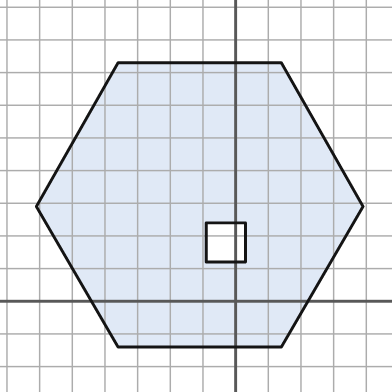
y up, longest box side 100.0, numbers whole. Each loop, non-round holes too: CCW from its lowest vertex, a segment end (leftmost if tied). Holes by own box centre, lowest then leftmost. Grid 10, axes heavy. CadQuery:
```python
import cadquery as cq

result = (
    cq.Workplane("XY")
    .moveTo(-36.0, -14.0)
    .lineTo(14.0, -14.0)
    .lineTo(39.0, 29.0)
    .lineTo(14.0, 73.0)
    .lineTo(-36.0, 73.0)
    .lineTo(-61.0, 29.0)
    .close()
    .moveTo(-9.0, 12.0)
    .lineTo(3.0, 12.0)
    .lineTo(3.0, 24.0)
    .lineTo(-9.0, 24.0)
    .close()
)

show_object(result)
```